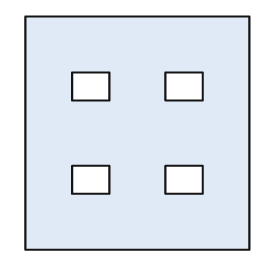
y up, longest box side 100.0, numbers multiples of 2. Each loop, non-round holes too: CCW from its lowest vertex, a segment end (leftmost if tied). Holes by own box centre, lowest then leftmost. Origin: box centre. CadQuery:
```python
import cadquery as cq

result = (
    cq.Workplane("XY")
    .moveTo(-48.0, -50.0)
    .lineTo(48.0, -50.0)
    .lineTo(48.0, 50.0)
    .lineTo(-48.0, 50.0)
    .close()
    .moveTo(-28.0, -26.0)
    .lineTo(-12.0, -26.0)
    .lineTo(-12.0, -14.0)
    .lineTo(-28.0, -14.0)
    .close()
    .moveTo(12.0, -26.0)
    .lineTo(28.0, -26.0)
    .lineTo(28.0, -14.0)
    .lineTo(12.0, -14.0)
    .close()
    .moveTo(-28.0, 14.0)
    .lineTo(-12.0, 14.0)
    .lineTo(-12.0, 26.0)
    .lineTo(-28.0, 26.0)
    .close()
    .moveTo(12.0, 14.0)
    .lineTo(28.0, 14.0)
    .lineTo(28.0, 26.0)
    .lineTo(12.0, 26.0)
    .close()
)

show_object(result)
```